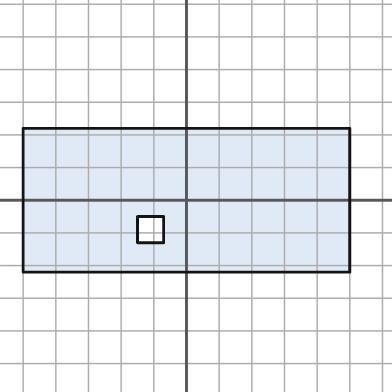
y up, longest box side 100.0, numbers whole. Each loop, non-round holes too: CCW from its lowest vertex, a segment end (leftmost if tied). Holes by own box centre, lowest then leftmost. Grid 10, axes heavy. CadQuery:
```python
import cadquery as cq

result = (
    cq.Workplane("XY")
    .moveTo(-50.0, -22.0)
    .lineTo(50.0, -22.0)
    .lineTo(50.0, 22.0)
    .lineTo(-50.0, 22.0)
    .close()
    .moveTo(-15.0, -13.0)
    .lineTo(-7.0, -13.0)
    .lineTo(-7.0, -5.0)
    .lineTo(-15.0, -5.0)
    .close()
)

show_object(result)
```